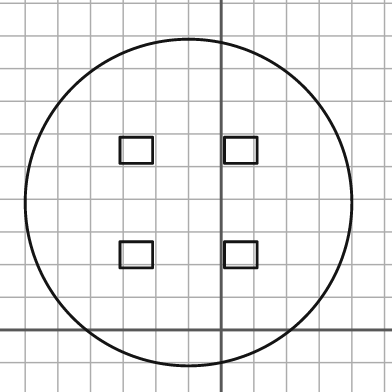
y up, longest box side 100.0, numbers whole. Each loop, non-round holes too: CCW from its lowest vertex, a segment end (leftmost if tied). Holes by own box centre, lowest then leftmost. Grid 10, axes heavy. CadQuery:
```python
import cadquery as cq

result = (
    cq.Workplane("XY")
    .moveTo(-10.0, 39.0)
    .circle(50.0)
    .moveTo(-31.0, 19.0)
    .lineTo(-21.0, 19.0)
    .lineTo(-21.0, 27.0)
    .lineTo(-31.0, 27.0)
    .close()
    .moveTo(1.0, 19.0)
    .lineTo(11.0, 19.0)
    .lineTo(11.0, 27.0)
    .lineTo(1.0, 27.0)
    .close()
    .moveTo(-31.0, 51.0)
    .lineTo(-21.0, 51.0)
    .lineTo(-21.0, 59.0)
    .lineTo(-31.0, 59.0)
    .close()
    .moveTo(1.0, 51.0)
    .lineTo(11.0, 51.0)
    .lineTo(11.0, 59.0)
    .lineTo(1.0, 59.0)
    .close()
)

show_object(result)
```